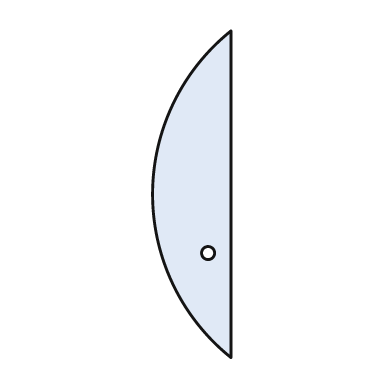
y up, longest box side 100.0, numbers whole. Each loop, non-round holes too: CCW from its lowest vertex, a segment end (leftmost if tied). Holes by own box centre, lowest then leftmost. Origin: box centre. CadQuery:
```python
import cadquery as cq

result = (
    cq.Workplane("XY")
    .moveTo(12.0, -50.0)
    .lineTo(12.0, 50.0)
    .threePointArc((-12.0, 0.0), (12.0, -50.0))
    .close()
    .moveTo(5.0, -18.0)
    .circle(2.0)
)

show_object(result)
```